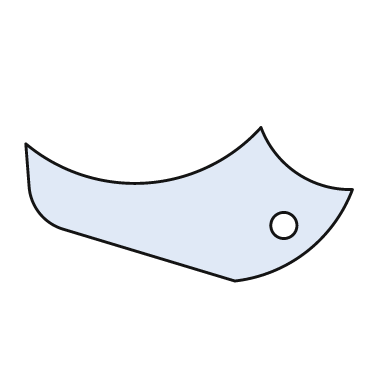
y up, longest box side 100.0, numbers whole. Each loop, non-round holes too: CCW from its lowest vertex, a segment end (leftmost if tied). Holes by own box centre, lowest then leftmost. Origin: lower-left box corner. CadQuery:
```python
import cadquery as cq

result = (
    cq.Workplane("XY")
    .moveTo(64.0, 0.0)
    .threePointArc((86.0, 9.0), (100.0, 28.0))
    .threePointArc((83.0, 33.0), (72.0, 47.0))
    .threePointArc((37.0, 30.0), (0.0, 42.0))
    .lineTo(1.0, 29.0)
    .threePointArc((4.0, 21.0), (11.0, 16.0))
    .close()
    .moveTo(79.0, 17.0)
    .circle(4.0)
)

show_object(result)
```